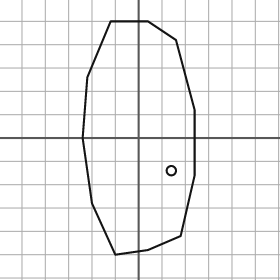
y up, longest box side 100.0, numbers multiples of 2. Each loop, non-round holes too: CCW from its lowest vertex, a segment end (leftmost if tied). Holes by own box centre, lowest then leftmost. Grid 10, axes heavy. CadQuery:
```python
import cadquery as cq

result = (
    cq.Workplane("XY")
    .moveTo(-10.0, -50.0)
    .lineTo(4.0, -48.0)
    .lineTo(18.0, -42.0)
    .lineTo(24.0, -16.0)
    .lineTo(24.0, 12.0)
    .lineTo(16.0, 42.0)
    .lineTo(4.0, 50.0)
    .lineTo(-12.0, 50.0)
    .lineTo(-22.0, 26.0)
    .lineTo(-24.0, 0.0)
    .lineTo(-20.0, -28.0)
    .close()
    .moveTo(14.0, -14.0)
    .circle(2.0)
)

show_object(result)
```